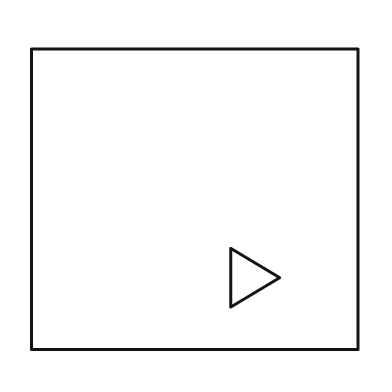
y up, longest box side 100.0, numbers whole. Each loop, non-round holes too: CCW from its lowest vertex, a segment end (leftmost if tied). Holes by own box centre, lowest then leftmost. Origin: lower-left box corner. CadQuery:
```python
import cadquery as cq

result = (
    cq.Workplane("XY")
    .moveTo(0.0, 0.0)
    .lineTo(100.0, 0.0)
    .lineTo(100.0, 92.0)
    .lineTo(0.0, 92.0)
    .close()
    .moveTo(61.0, 13.0)
    .lineTo(76.0, 22.0)
    .lineTo(61.0, 31.0)
    .close()
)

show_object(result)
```